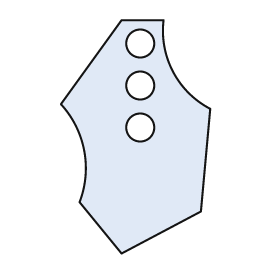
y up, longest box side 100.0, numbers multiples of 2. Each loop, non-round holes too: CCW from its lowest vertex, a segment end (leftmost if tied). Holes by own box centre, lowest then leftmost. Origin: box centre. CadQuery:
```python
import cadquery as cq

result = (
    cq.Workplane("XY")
    .moveTo(-6.0, -50.0)
    .lineTo(28.0, -32.0)
    .lineTo(32.0, 12.0)
    .threePointArc((16.0, 28.0), (12.0, 50.0))
    .lineTo(-6.0, 50.0)
    .lineTo(-32.0, 14.0)
    .threePointArc((-22.0, -6.0), (-24.0, -28.0))
    .close()
    .moveTo(2.0, 4.0)
    .circle(6.0)
    .moveTo(2.0, 22.0)
    .circle(6.0)
    .moveTo(2.0, 40.0)
    .circle(6.0)
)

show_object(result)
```